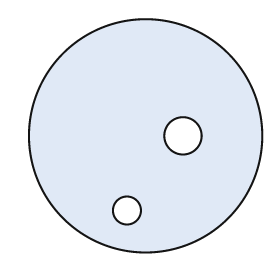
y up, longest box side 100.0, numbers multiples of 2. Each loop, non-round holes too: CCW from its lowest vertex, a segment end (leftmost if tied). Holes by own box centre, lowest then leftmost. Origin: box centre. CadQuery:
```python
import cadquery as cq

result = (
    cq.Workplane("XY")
    .moveTo(0.0, 0.0)
    .circle(50.0)
    .moveTo(-8.0, -32.0)
    .circle(6.0)
    .moveTo(16.0, 0.0)
    .circle(8.0)
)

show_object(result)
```